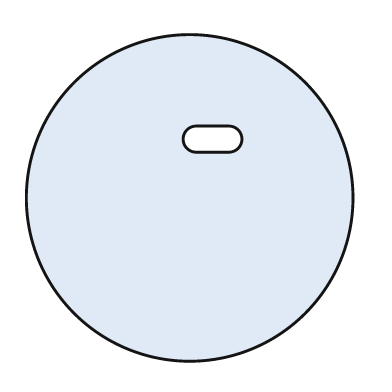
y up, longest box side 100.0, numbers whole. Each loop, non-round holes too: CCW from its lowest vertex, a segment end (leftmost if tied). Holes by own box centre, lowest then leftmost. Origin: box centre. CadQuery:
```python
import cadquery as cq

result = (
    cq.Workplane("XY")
    .moveTo(0.0, 0.0)
    .circle(50.0)
    .moveTo(2.0, 14.0)
    .lineTo(12.0, 14.0)
    .threePointArc((16.0, 18.0), (12.0, 22.0))
    .lineTo(2.0, 22.0)
    .threePointArc((-2.0, 18.0), (2.0, 14.0))
    .close()
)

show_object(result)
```